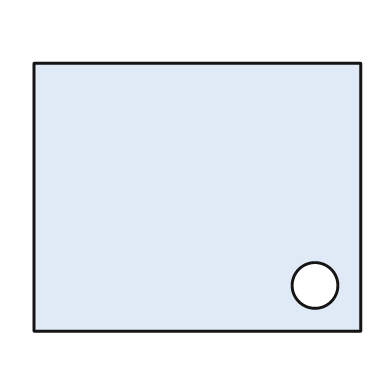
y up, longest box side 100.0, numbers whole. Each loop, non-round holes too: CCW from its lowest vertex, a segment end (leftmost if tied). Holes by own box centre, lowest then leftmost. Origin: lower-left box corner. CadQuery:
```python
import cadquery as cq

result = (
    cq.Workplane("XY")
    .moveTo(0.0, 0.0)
    .lineTo(100.0, 0.0)
    .lineTo(100.0, 82.0)
    .lineTo(0.0, 82.0)
    .close()
    .moveTo(86.0, 14.0)
    .circle(7.0)
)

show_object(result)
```